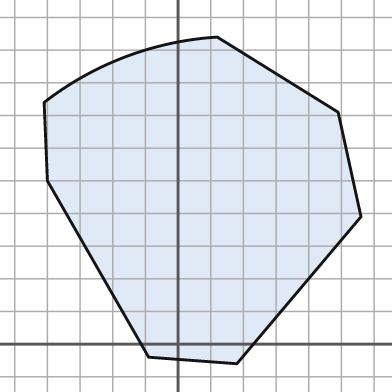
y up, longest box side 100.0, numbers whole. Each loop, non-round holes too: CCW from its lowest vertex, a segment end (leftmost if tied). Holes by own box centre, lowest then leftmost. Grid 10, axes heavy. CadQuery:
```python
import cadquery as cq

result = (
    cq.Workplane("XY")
    .moveTo(18.0, -6.0)
    .lineTo(56.0, 39.0)
    .lineTo(49.0, 71.0)
    .lineTo(12.0, 94.0)
    .threePointArc((-16.0, 88.0), (-41.0, 74.0))
    .lineTo(-40.0, 50.0)
    .lineTo(-9.0, -4.0)
    .close()
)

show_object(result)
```